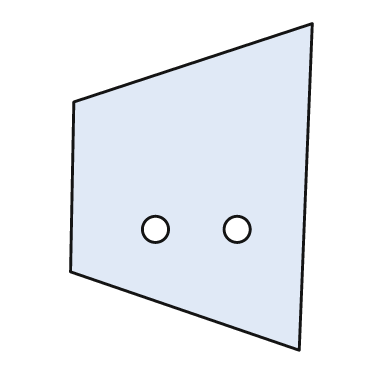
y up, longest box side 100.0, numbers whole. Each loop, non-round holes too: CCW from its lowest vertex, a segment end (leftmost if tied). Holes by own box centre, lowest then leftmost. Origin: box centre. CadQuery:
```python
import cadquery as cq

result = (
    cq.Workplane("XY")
    .moveTo(33.0, -50.0)
    .lineTo(37.0, 50.0)
    .lineTo(-36.0, 26.0)
    .lineTo(-37.0, -26.0)
    .close()
    .moveTo(-11.0, -13.0)
    .circle(4.0)
    .moveTo(14.0, -13.0)
    .circle(4.0)
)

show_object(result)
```